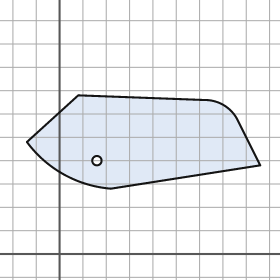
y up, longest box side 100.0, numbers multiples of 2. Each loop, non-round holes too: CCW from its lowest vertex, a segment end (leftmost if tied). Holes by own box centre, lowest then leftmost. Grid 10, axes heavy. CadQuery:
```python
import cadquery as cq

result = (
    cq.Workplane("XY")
    .moveTo(22.0, 28.0)
    .lineTo(86.0, 38.0)
    .lineTo(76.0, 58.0)
    .threePointArc((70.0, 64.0), (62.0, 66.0))
    .lineTo(8.0, 68.0)
    .lineTo(-14.0, 48.0)
    .threePointArc((2.0, 34.0), (22.0, 28.0))
    .close()
    .moveTo(16.0, 40.0)
    .circle(2.0)
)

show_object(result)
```